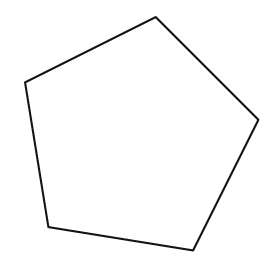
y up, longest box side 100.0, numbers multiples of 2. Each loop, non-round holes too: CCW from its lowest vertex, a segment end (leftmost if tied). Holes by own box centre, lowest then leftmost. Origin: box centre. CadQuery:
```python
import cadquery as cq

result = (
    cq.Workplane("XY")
    .moveTo(22.0, -50.0)
    .lineTo(50.0, 6.0)
    .lineTo(6.0, 50.0)
    .lineTo(-50.0, 22.0)
    .lineTo(-40.0, -40.0)
    .close()
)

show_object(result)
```